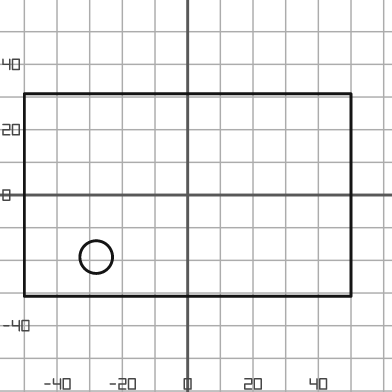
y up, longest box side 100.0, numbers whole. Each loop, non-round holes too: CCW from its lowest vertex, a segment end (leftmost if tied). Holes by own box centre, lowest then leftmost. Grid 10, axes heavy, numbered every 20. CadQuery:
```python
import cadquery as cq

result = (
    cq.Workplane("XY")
    .moveTo(-50.0, -31.0)
    .lineTo(50.0, -31.0)
    .lineTo(50.0, 31.0)
    .lineTo(-50.0, 31.0)
    .close()
    .moveTo(-28.0, -19.0)
    .circle(5.0)
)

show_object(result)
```